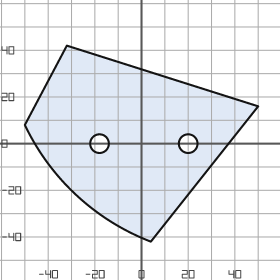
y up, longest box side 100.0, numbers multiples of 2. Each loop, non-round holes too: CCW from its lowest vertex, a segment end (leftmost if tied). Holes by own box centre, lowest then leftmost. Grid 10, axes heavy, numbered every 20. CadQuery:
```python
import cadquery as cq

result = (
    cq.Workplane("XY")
    .moveTo(4.0, -42.0)
    .lineTo(50.0, 16.0)
    .lineTo(-32.0, 42.0)
    .lineTo(-50.0, 8.0)
    .threePointArc((-28.0, -22.0), (4.0, -42.0))
    .close()
    .moveTo(-18.0, 0.0)
    .circle(4.0)
    .moveTo(20.0, 0.0)
    .circle(4.0)
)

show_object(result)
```